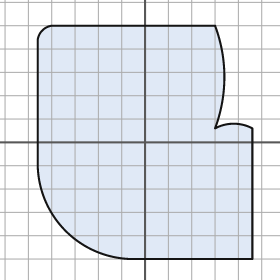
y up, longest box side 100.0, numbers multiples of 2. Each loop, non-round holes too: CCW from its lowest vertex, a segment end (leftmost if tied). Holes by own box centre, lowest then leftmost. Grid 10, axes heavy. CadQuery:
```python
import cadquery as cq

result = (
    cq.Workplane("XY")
    .moveTo(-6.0, -50.0)
    .lineTo(46.0, -50.0)
    .lineTo(46.0, 6.0)
    .threePointArc((38.0, 8.0), (30.0, 6.0))
    .threePointArc((34.0, 28.0), (30.0, 50.0))
    .lineTo(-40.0, 50.0)
    .threePointArc((-44.0, 48.0), (-46.0, 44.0))
    .lineTo(-46.0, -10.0)
    .threePointArc((-34.0, -38.0), (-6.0, -50.0))
    .close()
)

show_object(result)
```